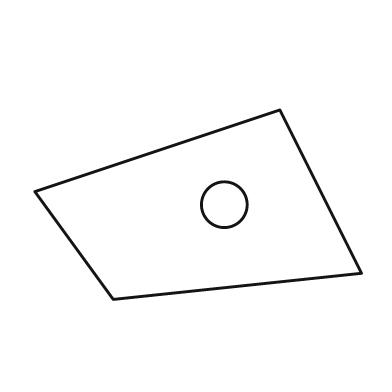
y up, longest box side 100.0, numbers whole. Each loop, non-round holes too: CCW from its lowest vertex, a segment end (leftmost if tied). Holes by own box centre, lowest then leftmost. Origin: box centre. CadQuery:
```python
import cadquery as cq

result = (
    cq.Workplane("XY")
    .moveTo(-26.0, -29.0)
    .lineTo(50.0, -21.0)
    .lineTo(25.0, 29.0)
    .lineTo(-50.0, 4.0)
    .close()
    .moveTo(8.0, 0.0)
    .circle(7.0)
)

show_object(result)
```